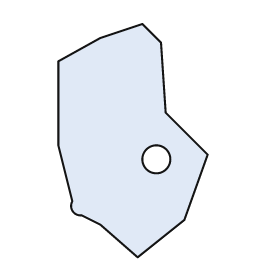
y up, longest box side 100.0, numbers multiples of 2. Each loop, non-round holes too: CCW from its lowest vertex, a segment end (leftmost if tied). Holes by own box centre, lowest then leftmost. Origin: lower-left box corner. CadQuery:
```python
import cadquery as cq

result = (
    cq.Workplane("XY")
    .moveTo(34.0, 0.0)
    .lineTo(54.0, 16.0)
    .lineTo(64.0, 44.0)
    .lineTo(46.0, 62.0)
    .lineTo(44.0, 92.0)
    .lineTo(36.0, 100.0)
    .lineTo(18.0, 94.0)
    .lineTo(0.0, 84.0)
    .lineTo(0.0, 48.0)
    .lineTo(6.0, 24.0)
    .threePointArc((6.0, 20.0), (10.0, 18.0))
    .lineTo(18.0, 14.0)
    .close()
    .moveTo(42.0, 42.0)
    .circle(6.0)
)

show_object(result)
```